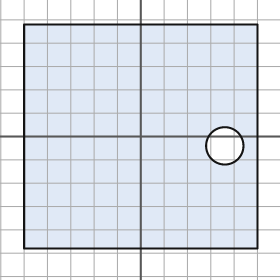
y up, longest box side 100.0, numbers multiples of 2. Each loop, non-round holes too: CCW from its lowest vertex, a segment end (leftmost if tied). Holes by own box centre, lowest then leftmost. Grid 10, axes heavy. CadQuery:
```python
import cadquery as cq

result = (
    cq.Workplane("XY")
    .moveTo(-50.0, -48.0)
    .lineTo(50.0, -48.0)
    .lineTo(50.0, 48.0)
    .lineTo(-50.0, 48.0)
    .close()
    .moveTo(36.0, -4.0)
    .circle(8.0)
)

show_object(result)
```